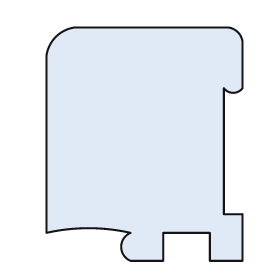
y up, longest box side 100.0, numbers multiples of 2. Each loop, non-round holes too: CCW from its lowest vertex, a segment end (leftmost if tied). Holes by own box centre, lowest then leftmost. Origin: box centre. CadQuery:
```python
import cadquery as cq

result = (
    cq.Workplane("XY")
    .moveTo(-6.0, -50.0)
    .lineTo(8.0, -50.0)
    .lineTo(8.0, -38.0)
    .lineTo(28.0, -38.0)
    .lineTo(28.0, -50.0)
    .lineTo(42.0, -50.0)
    .lineTo(42.0, -30.0)
    .lineTo(34.0, -30.0)
    .lineTo(34.0, 24.0)
    .threePointArc((38.0, 22.0), (42.0, 24.0))
    .lineTo(42.0, 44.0)
    .threePointArc((40.0, 48.0), (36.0, 50.0))
    .lineTo(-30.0, 50.0)
    .threePointArc((-38.0, 46.0), (-42.0, 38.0))
    .lineTo(-42.0, -38.0)
    .threePointArc((-24.0, -36.0), (-6.0, -38.0))
    .threePointArc((-10.0, -44.0), (-6.0, -50.0))
    .close()
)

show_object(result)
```